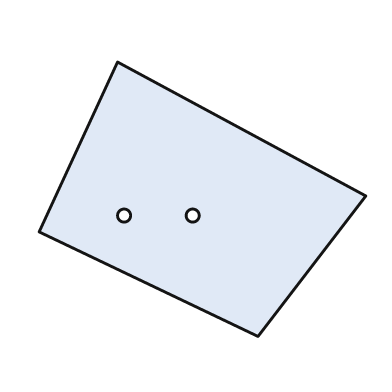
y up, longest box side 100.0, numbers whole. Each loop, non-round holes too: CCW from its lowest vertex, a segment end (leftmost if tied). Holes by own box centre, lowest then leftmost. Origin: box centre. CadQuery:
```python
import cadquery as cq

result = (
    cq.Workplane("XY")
    .moveTo(17.0, -42.0)
    .lineTo(50.0, 1.0)
    .lineTo(-26.0, 42.0)
    .lineTo(-50.0, -10.0)
    .close()
    .moveTo(-24.0, -5.0)
    .circle(2.0)
    .moveTo(-3.0, -5.0)
    .circle(2.0)
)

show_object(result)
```